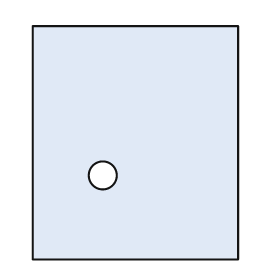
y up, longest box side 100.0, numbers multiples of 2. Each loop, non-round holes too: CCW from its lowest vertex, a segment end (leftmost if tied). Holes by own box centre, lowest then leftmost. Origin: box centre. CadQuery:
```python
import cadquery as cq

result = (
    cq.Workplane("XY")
    .moveTo(-44.0, -50.0)
    .lineTo(44.0, -50.0)
    .lineTo(44.0, 50.0)
    .lineTo(-44.0, 50.0)
    .close()
    .moveTo(-14.0, -14.0)
    .circle(6.0)
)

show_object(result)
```